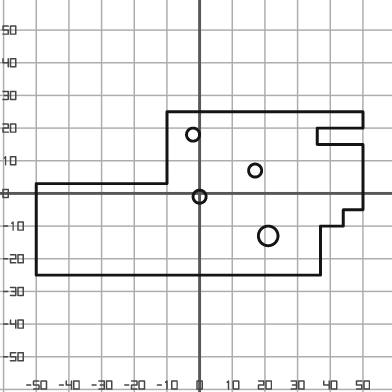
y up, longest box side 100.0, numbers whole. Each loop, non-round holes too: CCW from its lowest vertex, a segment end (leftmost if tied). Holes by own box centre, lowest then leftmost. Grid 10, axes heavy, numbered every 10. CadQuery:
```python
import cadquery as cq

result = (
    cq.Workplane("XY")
    .moveTo(-50.0, -25.0)
    .lineTo(37.0, -25.0)
    .lineTo(37.0, -10.0)
    .lineTo(44.0, -10.0)
    .lineTo(44.0, -5.0)
    .lineTo(50.0, -5.0)
    .lineTo(50.0, 15.0)
    .lineTo(36.0, 15.0)
    .lineTo(36.0, 20.0)
    .lineTo(50.0, 20.0)
    .lineTo(50.0, 25.0)
    .lineTo(-10.0, 25.0)
    .lineTo(-10.0, 3.0)
    .lineTo(-50.0, 3.0)
    .close()
    .moveTo(21.0, -13.0)
    .circle(3.0)
    .moveTo(0.0, -1.0)
    .circle(2.0)
    .moveTo(17.0, 7.0)
    .circle(2.0)
    .moveTo(-2.0, 18.0)
    .circle(2.0)
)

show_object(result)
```